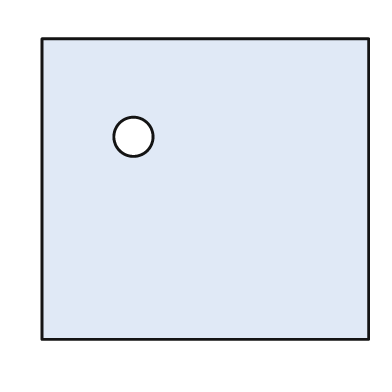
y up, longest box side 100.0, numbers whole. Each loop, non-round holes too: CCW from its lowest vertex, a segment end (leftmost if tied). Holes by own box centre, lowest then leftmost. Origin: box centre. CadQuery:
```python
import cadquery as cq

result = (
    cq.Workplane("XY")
    .moveTo(-50.0, -46.0)
    .lineTo(50.0, -46.0)
    .lineTo(50.0, 46.0)
    .lineTo(-50.0, 46.0)
    .close()
    .moveTo(-22.0, 16.0)
    .circle(6.0)
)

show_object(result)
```